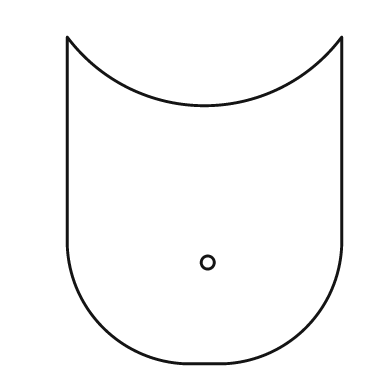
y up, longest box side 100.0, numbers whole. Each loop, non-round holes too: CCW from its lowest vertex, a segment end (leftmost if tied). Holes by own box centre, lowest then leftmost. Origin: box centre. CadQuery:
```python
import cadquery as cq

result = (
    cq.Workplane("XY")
    .moveTo(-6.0, -50.0)
    .lineTo(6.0, -50.0)
    .threePointArc((31.0, -39.0), (42.0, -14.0))
    .lineTo(42.0, 50.0)
    .threePointArc((0.0, 29.0), (-42.0, 50.0))
    .lineTo(-42.0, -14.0)
    .threePointArc((-31.0, -39.0), (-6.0, -50.0))
    .close()
    .moveTo(1.0, -19.0)
    .circle(2.0)
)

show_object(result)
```